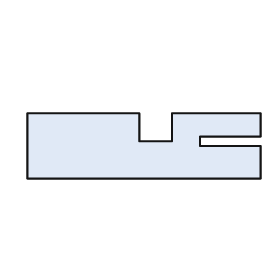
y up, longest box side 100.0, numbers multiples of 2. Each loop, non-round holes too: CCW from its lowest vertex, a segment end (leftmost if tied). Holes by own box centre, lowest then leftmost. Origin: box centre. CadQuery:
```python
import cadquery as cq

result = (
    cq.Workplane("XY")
    .moveTo(-50.0, -14.0)
    .lineTo(50.0, -14.0)
    .lineTo(50.0, 0.0)
    .lineTo(24.0, 0.0)
    .lineTo(24.0, 4.0)
    .lineTo(50.0, 4.0)
    .lineTo(50.0, 14.0)
    .lineTo(12.0, 14.0)
    .lineTo(12.0, 2.0)
    .lineTo(-2.0, 2.0)
    .lineTo(-2.0, 14.0)
    .lineTo(-50.0, 14.0)
    .close()
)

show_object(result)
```